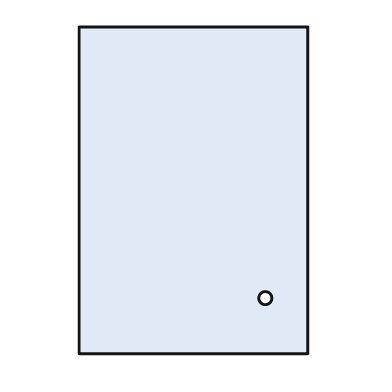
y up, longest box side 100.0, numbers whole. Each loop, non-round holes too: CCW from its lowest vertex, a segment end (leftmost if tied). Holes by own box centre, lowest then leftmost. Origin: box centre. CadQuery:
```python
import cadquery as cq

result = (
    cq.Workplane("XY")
    .moveTo(-35.0, -50.0)
    .lineTo(35.0, -50.0)
    .lineTo(35.0, 50.0)
    .lineTo(-35.0, 50.0)
    .close()
    .moveTo(22.0, -33.0)
    .circle(2.0)
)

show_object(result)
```